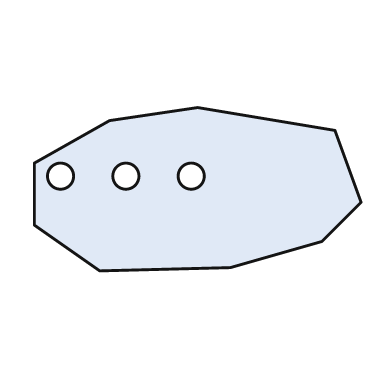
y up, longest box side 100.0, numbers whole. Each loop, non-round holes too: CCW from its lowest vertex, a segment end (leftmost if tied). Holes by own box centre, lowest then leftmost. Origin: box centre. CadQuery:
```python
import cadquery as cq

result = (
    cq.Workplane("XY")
    .moveTo(-30.0, -25.0)
    .lineTo(10.0, -24.0)
    .lineTo(38.0, -16.0)
    .lineTo(50.0, -4.0)
    .lineTo(42.0, 18.0)
    .lineTo(0.0, 25.0)
    .lineTo(-27.0, 21.0)
    .lineTo(-50.0, 8.0)
    .lineTo(-50.0, -11.0)
    .close()
    .moveTo(-42.0, 4.0)
    .circle(4.0)
    .moveTo(-22.0, 4.0)
    .circle(4.0)
    .moveTo(-2.0, 4.0)
    .circle(4.0)
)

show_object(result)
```